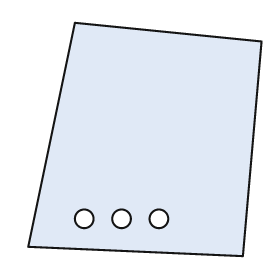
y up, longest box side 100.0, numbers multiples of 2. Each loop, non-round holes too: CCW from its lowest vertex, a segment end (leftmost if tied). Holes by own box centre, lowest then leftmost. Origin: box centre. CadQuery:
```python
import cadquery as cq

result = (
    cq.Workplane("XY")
    .moveTo(42.0, -50.0)
    .lineTo(50.0, 42.0)
    .lineTo(-30.0, 50.0)
    .lineTo(-50.0, -46.0)
    .close()
    .moveTo(-26.0, -34.0)
    .circle(4.0)
    .moveTo(-10.0, -34.0)
    .circle(4.0)
    .moveTo(6.0, -34.0)
    .circle(4.0)
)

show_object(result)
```